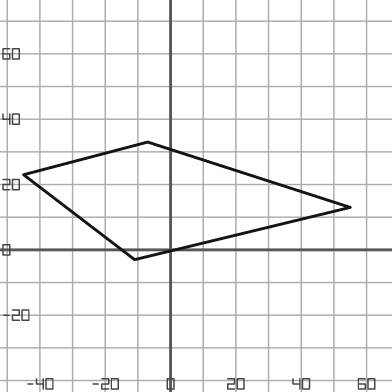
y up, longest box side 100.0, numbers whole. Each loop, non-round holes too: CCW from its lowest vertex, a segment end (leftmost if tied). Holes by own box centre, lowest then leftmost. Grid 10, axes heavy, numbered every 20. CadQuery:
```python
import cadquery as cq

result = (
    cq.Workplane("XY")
    .moveTo(-11.0, -3.0)
    .lineTo(55.0, 13.0)
    .lineTo(-7.0, 33.0)
    .lineTo(-45.0, 23.0)
    .close()
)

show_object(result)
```